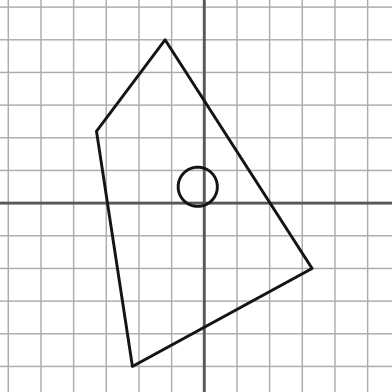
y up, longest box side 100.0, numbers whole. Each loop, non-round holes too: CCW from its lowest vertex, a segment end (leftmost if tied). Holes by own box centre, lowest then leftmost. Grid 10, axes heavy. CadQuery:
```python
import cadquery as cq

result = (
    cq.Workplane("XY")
    .moveTo(-22.0, -50.0)
    .lineTo(33.0, -20.0)
    .lineTo(-12.0, 50.0)
    .lineTo(-33.0, 22.0)
    .close()
    .moveTo(-2.0, 5.0)
    .circle(6.0)
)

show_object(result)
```